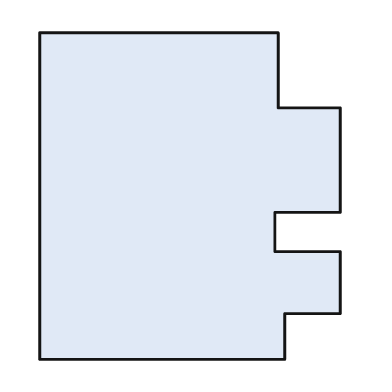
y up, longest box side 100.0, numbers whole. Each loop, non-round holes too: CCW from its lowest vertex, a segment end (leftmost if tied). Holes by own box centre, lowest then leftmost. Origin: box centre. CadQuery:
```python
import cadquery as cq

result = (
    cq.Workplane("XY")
    .moveTo(-46.0, -50.0)
    .lineTo(29.0, -50.0)
    .lineTo(29.0, -36.0)
    .lineTo(46.0, -36.0)
    .lineTo(46.0, -17.0)
    .lineTo(26.0, -17.0)
    .lineTo(26.0, -5.0)
    .lineTo(46.0, -5.0)
    .lineTo(46.0, 27.0)
    .lineTo(27.0, 27.0)
    .lineTo(27.0, 50.0)
    .lineTo(-46.0, 50.0)
    .close()
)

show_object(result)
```